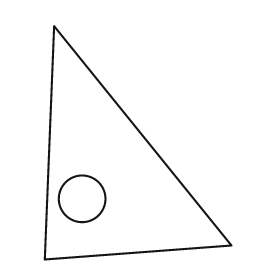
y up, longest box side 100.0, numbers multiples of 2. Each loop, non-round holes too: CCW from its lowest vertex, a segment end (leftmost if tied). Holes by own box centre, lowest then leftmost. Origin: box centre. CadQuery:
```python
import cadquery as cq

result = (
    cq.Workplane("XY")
    .moveTo(-40.0, -50.0)
    .lineTo(40.0, -44.0)
    .lineTo(-36.0, 50.0)
    .close()
    .moveTo(-24.0, -24.0)
    .circle(10.0)
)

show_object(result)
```